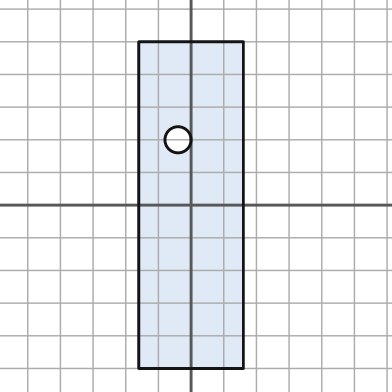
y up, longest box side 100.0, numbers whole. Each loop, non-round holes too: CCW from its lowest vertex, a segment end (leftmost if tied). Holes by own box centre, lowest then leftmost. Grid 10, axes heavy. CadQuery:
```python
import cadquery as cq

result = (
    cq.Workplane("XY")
    .moveTo(-16.0, -50.0)
    .lineTo(16.0, -50.0)
    .lineTo(16.0, 50.0)
    .lineTo(-16.0, 50.0)
    .close()
    .moveTo(-4.0, 20.0)
    .circle(4.0)
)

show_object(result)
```